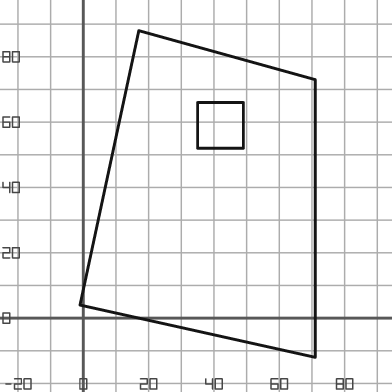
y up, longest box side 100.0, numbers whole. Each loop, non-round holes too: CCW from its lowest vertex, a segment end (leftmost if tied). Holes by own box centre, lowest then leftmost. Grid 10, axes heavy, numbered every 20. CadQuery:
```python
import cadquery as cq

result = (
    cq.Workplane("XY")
    .moveTo(71.0, -12.0)
    .lineTo(71.0, 73.0)
    .lineTo(17.0, 88.0)
    .lineTo(-1.0, 4.0)
    .close()
    .moveTo(35.0, 52.0)
    .lineTo(49.0, 52.0)
    .lineTo(49.0, 66.0)
    .lineTo(35.0, 66.0)
    .close()
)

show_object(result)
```